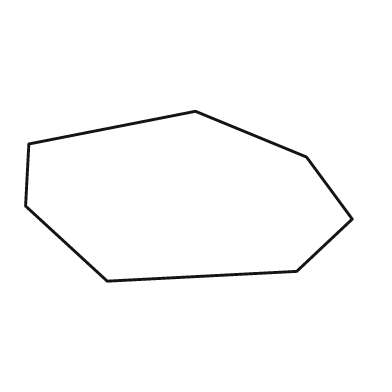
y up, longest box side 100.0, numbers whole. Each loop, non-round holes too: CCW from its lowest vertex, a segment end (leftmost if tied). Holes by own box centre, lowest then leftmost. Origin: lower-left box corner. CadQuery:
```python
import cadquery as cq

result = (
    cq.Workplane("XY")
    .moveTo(25.0, 0.0)
    .lineTo(83.0, 3.0)
    .lineTo(100.0, 19.0)
    .lineTo(86.0, 38.0)
    .lineTo(52.0, 52.0)
    .lineTo(1.0, 42.0)
    .lineTo(0.0, 23.0)
    .close()
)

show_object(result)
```